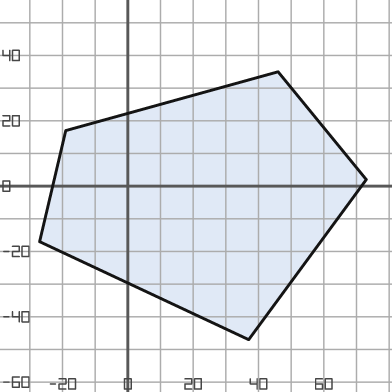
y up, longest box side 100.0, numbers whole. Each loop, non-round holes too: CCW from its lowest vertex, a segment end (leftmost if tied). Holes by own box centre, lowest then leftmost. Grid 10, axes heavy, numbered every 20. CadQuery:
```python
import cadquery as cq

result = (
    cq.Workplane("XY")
    .moveTo(37.0, -47.0)
    .lineTo(73.0, 2.0)
    .lineTo(46.0, 35.0)
    .lineTo(-19.0, 17.0)
    .lineTo(-27.0, -17.0)
    .close()
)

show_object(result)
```